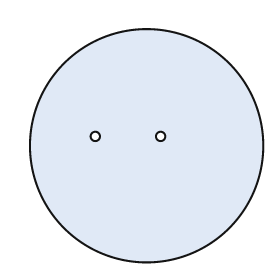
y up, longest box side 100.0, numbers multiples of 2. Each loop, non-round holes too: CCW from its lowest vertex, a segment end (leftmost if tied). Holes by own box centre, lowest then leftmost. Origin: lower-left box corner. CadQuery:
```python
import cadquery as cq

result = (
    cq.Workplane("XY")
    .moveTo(50.0, 50.0)
    .circle(50.0)
    .moveTo(28.0, 54.0)
    .circle(2.0)
    .moveTo(56.0, 54.0)
    .circle(2.0)
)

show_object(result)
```